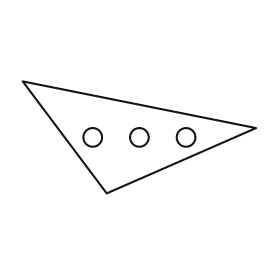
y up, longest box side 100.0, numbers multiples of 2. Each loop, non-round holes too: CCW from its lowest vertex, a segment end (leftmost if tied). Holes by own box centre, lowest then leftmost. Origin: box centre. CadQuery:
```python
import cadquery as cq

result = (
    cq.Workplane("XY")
    .moveTo(-14.0, -24.0)
    .lineTo(50.0, 4.0)
    .lineTo(-50.0, 24.0)
    .close()
    .moveTo(-20.0, 0.0)
    .circle(4.0)
    .moveTo(0.0, 0.0)
    .circle(4.0)
    .moveTo(20.0, 0.0)
    .circle(4.0)
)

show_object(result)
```